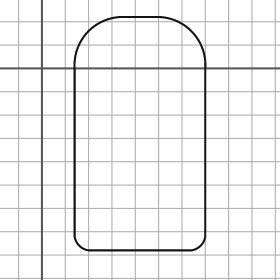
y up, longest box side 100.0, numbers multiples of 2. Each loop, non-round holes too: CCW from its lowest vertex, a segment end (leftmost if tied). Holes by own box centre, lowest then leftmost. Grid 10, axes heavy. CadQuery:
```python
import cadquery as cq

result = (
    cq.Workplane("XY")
    .moveTo(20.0, -78.0)
    .lineTo(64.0, -78.0)
    .threePointArc((68.0, -76.0), (70.0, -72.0))
    .lineTo(70.0, 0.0)
    .threePointArc((64.0, 16.0), (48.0, 22.0))
    .lineTo(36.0, 22.0)
    .threePointArc((20.0, 16.0), (14.0, 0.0))
    .lineTo(14.0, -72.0)
    .threePointArc((16.0, -76.0), (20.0, -78.0))
    .close()
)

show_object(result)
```